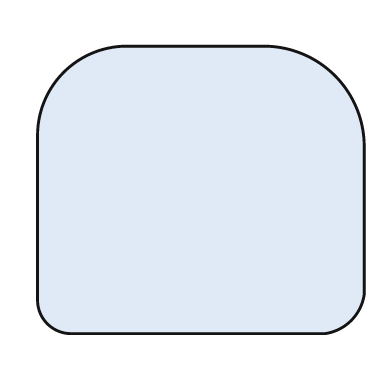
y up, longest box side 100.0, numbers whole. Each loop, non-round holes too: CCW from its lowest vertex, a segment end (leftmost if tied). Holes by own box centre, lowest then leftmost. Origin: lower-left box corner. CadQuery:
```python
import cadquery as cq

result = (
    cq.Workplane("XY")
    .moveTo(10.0, 0.0)
    .lineTo(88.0, 0.0)
    .threePointArc((96.0, 4.0), (100.0, 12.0))
    .lineTo(100.0, 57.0)
    .threePointArc((91.0, 79.0), (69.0, 88.0))
    .lineTo(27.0, 88.0)
    .threePointArc((8.0, 80.0), (0.0, 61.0))
    .lineTo(0.0, 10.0)
    .threePointArc((3.0, 3.0), (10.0, 0.0))
    .close()
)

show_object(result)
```